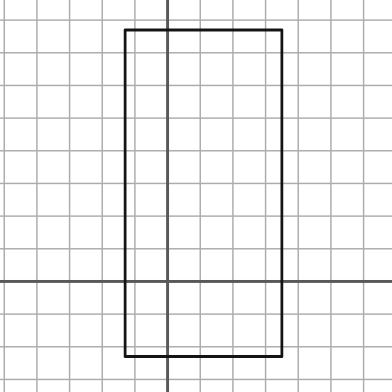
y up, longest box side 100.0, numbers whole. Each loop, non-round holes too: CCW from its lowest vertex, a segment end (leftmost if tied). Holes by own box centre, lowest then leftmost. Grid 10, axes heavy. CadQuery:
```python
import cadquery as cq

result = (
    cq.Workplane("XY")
    .moveTo(-13.0, -23.0)
    .lineTo(35.0, -23.0)
    .lineTo(35.0, 77.0)
    .lineTo(-13.0, 77.0)
    .close()
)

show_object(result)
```